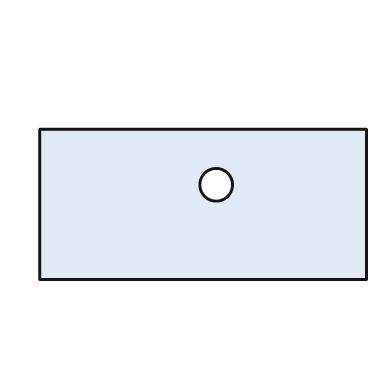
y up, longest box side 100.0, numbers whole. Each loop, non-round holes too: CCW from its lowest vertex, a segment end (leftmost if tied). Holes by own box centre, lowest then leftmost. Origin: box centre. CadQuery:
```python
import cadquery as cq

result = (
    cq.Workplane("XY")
    .moveTo(-50.0, -23.0)
    .lineTo(50.0, -23.0)
    .lineTo(50.0, 23.0)
    .lineTo(-50.0, 23.0)
    .close()
    .moveTo(4.0, 6.0)
    .circle(5.0)
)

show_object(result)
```